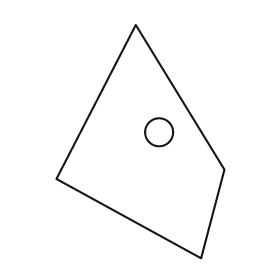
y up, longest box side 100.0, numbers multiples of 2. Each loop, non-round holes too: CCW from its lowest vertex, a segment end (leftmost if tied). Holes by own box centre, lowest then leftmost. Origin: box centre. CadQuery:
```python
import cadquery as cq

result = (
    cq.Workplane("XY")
    .moveTo(26.0, -50.0)
    .lineTo(36.0, -12.0)
    .lineTo(-2.0, 50.0)
    .lineTo(-36.0, -16.0)
    .close()
    .moveTo(8.0, 4.0)
    .circle(6.0)
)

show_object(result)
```